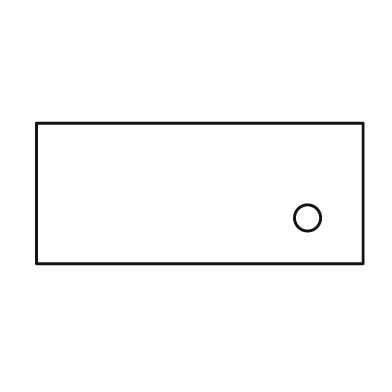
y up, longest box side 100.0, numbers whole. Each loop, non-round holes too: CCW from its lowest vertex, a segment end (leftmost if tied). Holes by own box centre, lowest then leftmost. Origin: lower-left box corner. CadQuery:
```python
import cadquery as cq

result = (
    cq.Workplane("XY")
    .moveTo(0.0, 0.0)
    .lineTo(100.0, 0.0)
    .lineTo(100.0, 43.0)
    .lineTo(0.0, 43.0)
    .close()
    .moveTo(83.0, 14.0)
    .circle(4.0)
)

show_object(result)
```